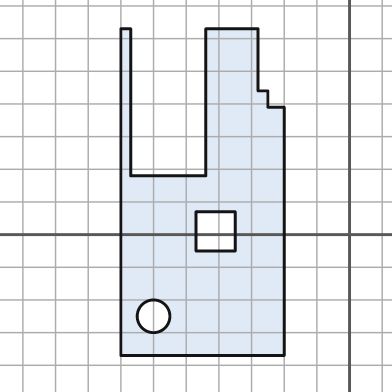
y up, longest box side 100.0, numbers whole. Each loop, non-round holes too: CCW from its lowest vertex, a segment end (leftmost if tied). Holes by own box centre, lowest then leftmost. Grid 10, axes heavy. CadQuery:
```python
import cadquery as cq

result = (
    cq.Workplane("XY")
    .moveTo(-70.0, -37.0)
    .lineTo(-20.0, -37.0)
    .lineTo(-20.0, 39.0)
    .lineTo(-25.0, 39.0)
    .lineTo(-25.0, 44.0)
    .lineTo(-28.0, 44.0)
    .lineTo(-28.0, 63.0)
    .lineTo(-44.0, 63.0)
    .lineTo(-44.0, 18.0)
    .lineTo(-67.0, 18.0)
    .lineTo(-67.0, 63.0)
    .lineTo(-70.0, 63.0)
    .close()
    .moveTo(-60.0, -25.0)
    .circle(5.0)
    .moveTo(-47.0, -5.0)
    .lineTo(-35.0, -5.0)
    .lineTo(-35.0, 7.0)
    .lineTo(-47.0, 7.0)
    .close()
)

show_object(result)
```